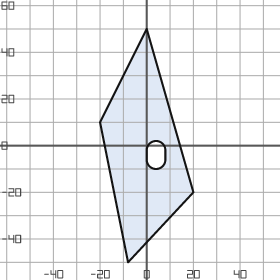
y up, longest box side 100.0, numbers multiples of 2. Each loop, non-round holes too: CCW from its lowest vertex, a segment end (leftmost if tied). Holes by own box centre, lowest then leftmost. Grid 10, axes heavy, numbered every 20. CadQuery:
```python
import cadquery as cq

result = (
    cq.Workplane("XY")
    .moveTo(-8.0, -50.0)
    .lineTo(20.0, -20.0)
    .lineTo(0.0, 50.0)
    .lineTo(-20.0, 10.0)
    .close()
    .moveTo(0.0, -6.0)
    .threePointArc((4.0, -10.0), (8.0, -6.0))
    .lineTo(8.0, -2.0)
    .threePointArc((4.0, 2.0), (0.0, -2.0))
    .close()
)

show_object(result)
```